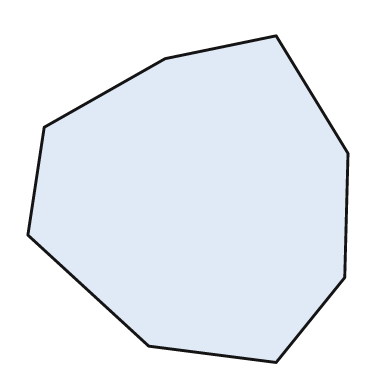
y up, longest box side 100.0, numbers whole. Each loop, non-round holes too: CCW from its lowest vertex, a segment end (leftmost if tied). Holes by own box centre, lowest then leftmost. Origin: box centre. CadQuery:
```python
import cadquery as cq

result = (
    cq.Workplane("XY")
    .moveTo(27.0, -50.0)
    .lineTo(48.0, -24.0)
    .lineTo(49.0, 14.0)
    .lineTo(27.0, 50.0)
    .lineTo(-7.0, 43.0)
    .lineTo(-44.0, 22.0)
    .lineTo(-49.0, -11.0)
    .lineTo(-12.0, -45.0)
    .close()
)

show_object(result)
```